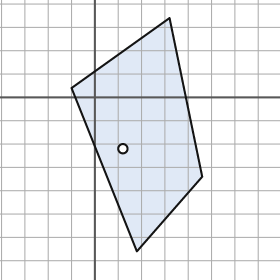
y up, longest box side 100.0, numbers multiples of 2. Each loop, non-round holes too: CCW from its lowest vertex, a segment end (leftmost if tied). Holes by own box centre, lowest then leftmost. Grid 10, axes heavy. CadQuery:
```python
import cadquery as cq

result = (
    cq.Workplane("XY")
    .moveTo(18.0, -66.0)
    .lineTo(46.0, -34.0)
    .lineTo(32.0, 34.0)
    .lineTo(-10.0, 4.0)
    .close()
    .moveTo(12.0, -22.0)
    .circle(2.0)
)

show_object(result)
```